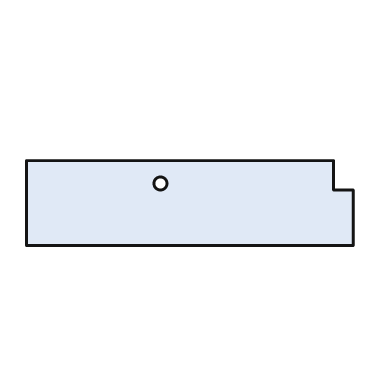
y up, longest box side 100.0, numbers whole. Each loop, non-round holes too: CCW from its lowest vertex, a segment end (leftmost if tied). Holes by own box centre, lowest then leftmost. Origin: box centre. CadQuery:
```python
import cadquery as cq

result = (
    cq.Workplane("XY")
    .moveTo(-50.0, -13.0)
    .lineTo(50.0, -13.0)
    .lineTo(50.0, 4.0)
    .lineTo(44.0, 4.0)
    .lineTo(44.0, 13.0)
    .lineTo(-50.0, 13.0)
    .close()
    .moveTo(-9.0, 6.0)
    .circle(2.0)
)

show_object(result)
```